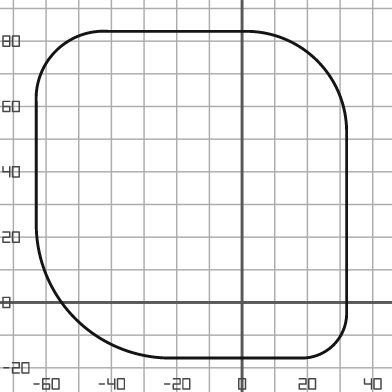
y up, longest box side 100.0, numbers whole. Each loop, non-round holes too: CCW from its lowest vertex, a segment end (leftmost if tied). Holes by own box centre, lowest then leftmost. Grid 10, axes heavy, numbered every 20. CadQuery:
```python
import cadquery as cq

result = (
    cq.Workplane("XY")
    .moveTo(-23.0, -17.0)
    .lineTo(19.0, -17.0)
    .threePointArc((28.0, -13.0), (32.0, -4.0))
    .lineTo(32.0, 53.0)
    .threePointArc((23.0, 74.0), (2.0, 83.0))
    .lineTo(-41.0, 83.0)
    .threePointArc((-57.0, 77.0), (-63.0, 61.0))
    .lineTo(-63.0, 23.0)
    .threePointArc((-51.0, -5.0), (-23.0, -17.0))
    .close()
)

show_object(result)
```